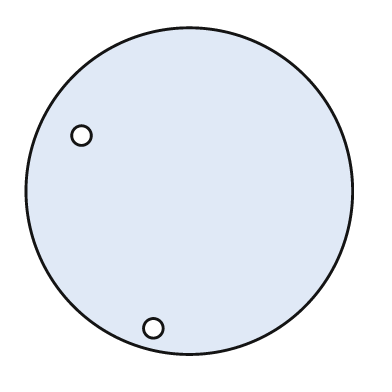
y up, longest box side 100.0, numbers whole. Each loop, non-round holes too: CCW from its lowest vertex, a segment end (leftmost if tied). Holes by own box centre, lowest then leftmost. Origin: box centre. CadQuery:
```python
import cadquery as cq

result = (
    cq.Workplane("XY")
    .moveTo(0.0, 0.0)
    .circle(50.0)
    .moveTo(-11.0, -42.0)
    .circle(3.0)
    .moveTo(-33.0, 17.0)
    .circle(3.0)
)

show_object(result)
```